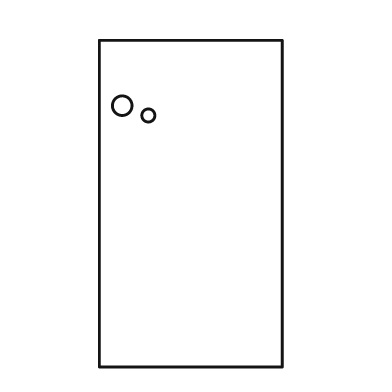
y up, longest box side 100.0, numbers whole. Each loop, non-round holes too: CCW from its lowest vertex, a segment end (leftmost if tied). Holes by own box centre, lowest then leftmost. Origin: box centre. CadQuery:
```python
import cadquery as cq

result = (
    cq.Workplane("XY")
    .moveTo(-28.0, -50.0)
    .lineTo(28.0, -50.0)
    .lineTo(28.0, 50.0)
    .lineTo(-28.0, 50.0)
    .close()
    .moveTo(-13.0, 27.0)
    .circle(2.0)
    .moveTo(-21.0, 30.0)
    .circle(3.0)
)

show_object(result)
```